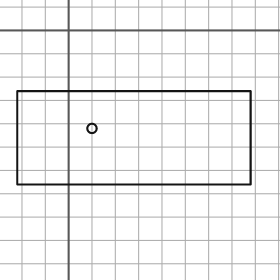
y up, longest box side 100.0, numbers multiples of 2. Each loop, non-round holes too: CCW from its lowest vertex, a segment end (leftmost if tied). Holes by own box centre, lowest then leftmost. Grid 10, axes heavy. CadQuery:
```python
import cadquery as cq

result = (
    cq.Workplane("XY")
    .moveTo(-22.0, -66.0)
    .lineTo(78.0, -66.0)
    .lineTo(78.0, -26.0)
    .lineTo(-22.0, -26.0)
    .close()
    .moveTo(10.0, -42.0)
    .circle(2.0)
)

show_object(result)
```